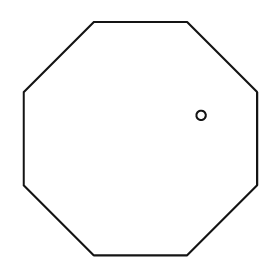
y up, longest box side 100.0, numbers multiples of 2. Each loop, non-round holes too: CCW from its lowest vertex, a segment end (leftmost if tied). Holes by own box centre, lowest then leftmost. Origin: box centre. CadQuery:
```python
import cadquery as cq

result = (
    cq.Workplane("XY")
    .moveTo(-20.0, -50.0)
    .lineTo(20.0, -50.0)
    .lineTo(50.0, -20.0)
    .lineTo(50.0, 20.0)
    .lineTo(20.0, 50.0)
    .lineTo(-20.0, 50.0)
    .lineTo(-50.0, 20.0)
    .lineTo(-50.0, -20.0)
    .close()
    .moveTo(26.0, 10.0)
    .circle(2.0)
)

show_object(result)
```